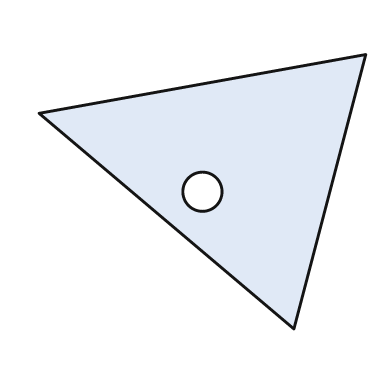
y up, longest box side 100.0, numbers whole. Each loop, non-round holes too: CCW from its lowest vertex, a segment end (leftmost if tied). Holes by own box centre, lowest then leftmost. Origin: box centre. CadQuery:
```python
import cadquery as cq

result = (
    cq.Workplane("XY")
    .moveTo(28.0, -42.0)
    .lineTo(50.0, 42.0)
    .lineTo(-50.0, 24.0)
    .close()
    .moveTo(0.0, 0.0)
    .circle(6.0)
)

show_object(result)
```